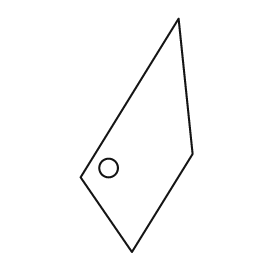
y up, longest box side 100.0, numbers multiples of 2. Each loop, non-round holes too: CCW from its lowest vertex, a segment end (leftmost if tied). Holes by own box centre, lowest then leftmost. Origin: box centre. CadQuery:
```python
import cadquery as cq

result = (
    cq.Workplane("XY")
    .moveTo(-2.0, -50.0)
    .lineTo(24.0, -8.0)
    .lineTo(18.0, 50.0)
    .lineTo(-24.0, -18.0)
    .close()
    .moveTo(-12.0, -14.0)
    .circle(4.0)
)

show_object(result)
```